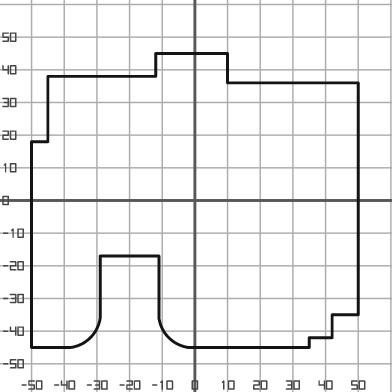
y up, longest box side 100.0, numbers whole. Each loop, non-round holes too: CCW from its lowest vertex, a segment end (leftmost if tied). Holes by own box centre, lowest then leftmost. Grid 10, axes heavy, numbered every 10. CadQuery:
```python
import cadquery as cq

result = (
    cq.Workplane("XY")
    .moveTo(-50.0, -45.0)
    .lineTo(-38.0, -45.0)
    .threePointArc((-32.0, -42.0), (-29.0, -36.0))
    .lineTo(-29.0, -17.0)
    .lineTo(-11.0, -17.0)
    .lineTo(-11.0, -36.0)
    .threePointArc((-8.0, -42.0), (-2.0, -45.0))
    .lineTo(35.0, -45.0)
    .lineTo(35.0, -42.0)
    .lineTo(42.0, -42.0)
    .lineTo(42.0, -35.0)
    .lineTo(50.0, -35.0)
    .lineTo(50.0, 36.0)
    .lineTo(10.0, 36.0)
    .lineTo(10.0, 45.0)
    .lineTo(-12.0, 45.0)
    .lineTo(-12.0, 38.0)
    .lineTo(-45.0, 38.0)
    .lineTo(-45.0, 18.0)
    .lineTo(-50.0, 18.0)
    .close()
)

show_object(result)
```